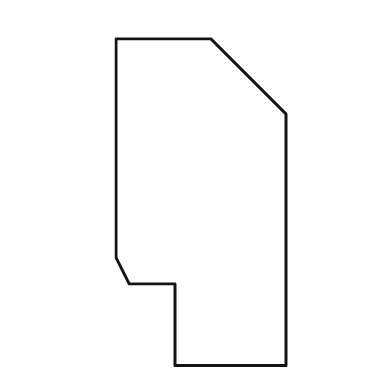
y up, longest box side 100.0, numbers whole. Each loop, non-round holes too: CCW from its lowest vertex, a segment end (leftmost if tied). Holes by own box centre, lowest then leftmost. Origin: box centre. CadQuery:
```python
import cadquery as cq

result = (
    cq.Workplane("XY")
    .moveTo(-8.0, -50.0)
    .lineTo(26.0, -50.0)
    .lineTo(26.0, 27.0)
    .lineTo(3.0, 50.0)
    .lineTo(-26.0, 50.0)
    .lineTo(-26.0, -17.0)
    .lineTo(-22.0, -25.0)
    .lineTo(-8.0, -25.0)
    .close()
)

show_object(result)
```